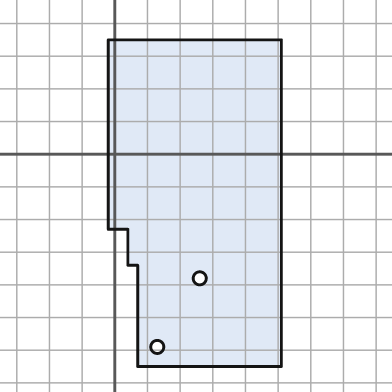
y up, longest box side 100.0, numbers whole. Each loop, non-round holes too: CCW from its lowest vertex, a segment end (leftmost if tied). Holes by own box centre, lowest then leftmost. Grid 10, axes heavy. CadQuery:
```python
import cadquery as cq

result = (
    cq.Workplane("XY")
    .moveTo(7.0, -65.0)
    .lineTo(51.0, -65.0)
    .lineTo(51.0, 35.0)
    .lineTo(-2.0, 35.0)
    .lineTo(-2.0, -23.0)
    .lineTo(4.0, -23.0)
    .lineTo(4.0, -34.0)
    .lineTo(7.0, -34.0)
    .close()
    .moveTo(13.0, -59.0)
    .circle(2.0)
    .moveTo(26.0, -38.0)
    .circle(2.0)
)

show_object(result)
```